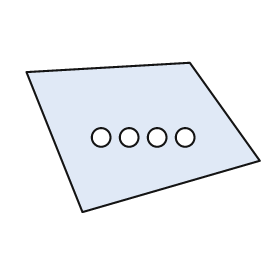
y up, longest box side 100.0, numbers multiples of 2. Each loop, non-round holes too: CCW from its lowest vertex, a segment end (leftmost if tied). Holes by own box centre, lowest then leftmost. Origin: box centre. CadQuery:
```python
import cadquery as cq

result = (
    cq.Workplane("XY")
    .moveTo(-26.0, -32.0)
    .lineTo(50.0, -10.0)
    .lineTo(20.0, 32.0)
    .lineTo(-50.0, 28.0)
    .close()
    .moveTo(-18.0, 0.0)
    .circle(4.0)
    .moveTo(-6.0, 0.0)
    .circle(4.0)
    .moveTo(6.0, 0.0)
    .circle(4.0)
    .moveTo(18.0, 0.0)
    .circle(4.0)
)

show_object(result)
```